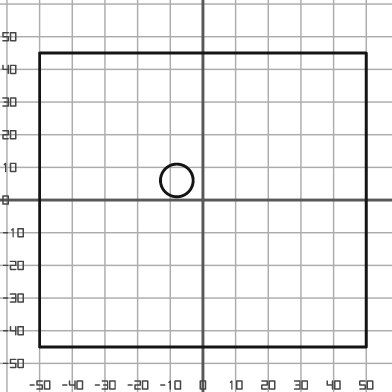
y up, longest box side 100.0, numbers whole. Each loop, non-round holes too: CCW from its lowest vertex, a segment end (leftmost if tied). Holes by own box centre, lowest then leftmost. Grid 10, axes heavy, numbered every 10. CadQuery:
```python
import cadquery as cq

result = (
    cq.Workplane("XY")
    .moveTo(-50.0, -45.0)
    .lineTo(50.0, -45.0)
    .lineTo(50.0, 45.0)
    .lineTo(-50.0, 45.0)
    .close()
    .moveTo(-8.0, 6.0)
    .circle(5.0)
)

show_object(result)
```